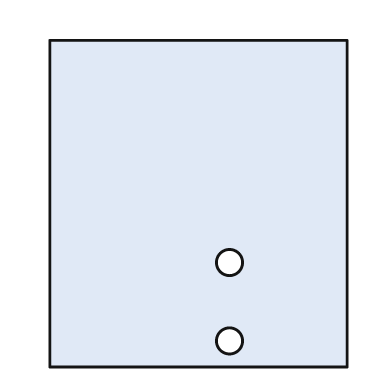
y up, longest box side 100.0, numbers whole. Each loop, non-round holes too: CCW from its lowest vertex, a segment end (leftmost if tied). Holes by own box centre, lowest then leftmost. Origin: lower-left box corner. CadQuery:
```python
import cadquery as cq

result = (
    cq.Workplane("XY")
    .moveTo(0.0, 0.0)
    .lineTo(91.0, 0.0)
    .lineTo(91.0, 100.0)
    .lineTo(0.0, 100.0)
    .close()
    .moveTo(55.0, 8.0)
    .circle(4.0)
    .moveTo(55.0, 32.0)
    .circle(4.0)
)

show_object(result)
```